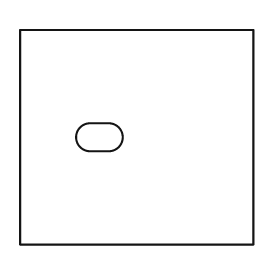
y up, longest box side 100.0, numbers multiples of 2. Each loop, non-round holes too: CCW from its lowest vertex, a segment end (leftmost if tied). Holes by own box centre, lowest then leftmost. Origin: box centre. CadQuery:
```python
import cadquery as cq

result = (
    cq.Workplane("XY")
    .moveTo(-50.0, -46.0)
    .lineTo(50.0, -46.0)
    .lineTo(50.0, 46.0)
    .lineTo(-50.0, 46.0)
    .close()
    .moveTo(-20.0, -6.0)
    .lineTo(-12.0, -6.0)
    .threePointArc((-6.0, 0.0), (-12.0, 6.0))
    .lineTo(-20.0, 6.0)
    .threePointArc((-26.0, 0.0), (-20.0, -6.0))
    .close()
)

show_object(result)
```